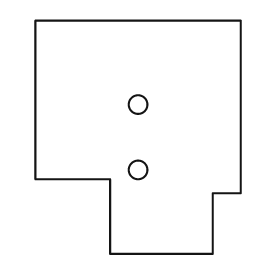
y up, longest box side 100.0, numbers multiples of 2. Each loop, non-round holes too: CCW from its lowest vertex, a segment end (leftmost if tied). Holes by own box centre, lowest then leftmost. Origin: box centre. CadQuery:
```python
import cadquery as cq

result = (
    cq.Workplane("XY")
    .moveTo(-12.0, -50.0)
    .lineTo(32.0, -50.0)
    .lineTo(32.0, -24.0)
    .lineTo(44.0, -24.0)
    .lineTo(44.0, 50.0)
    .lineTo(-44.0, 50.0)
    .lineTo(-44.0, -18.0)
    .lineTo(-12.0, -18.0)
    .close()
    .moveTo(0.0, -14.0)
    .circle(4.0)
    .moveTo(0.0, 14.0)
    .circle(4.0)
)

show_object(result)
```